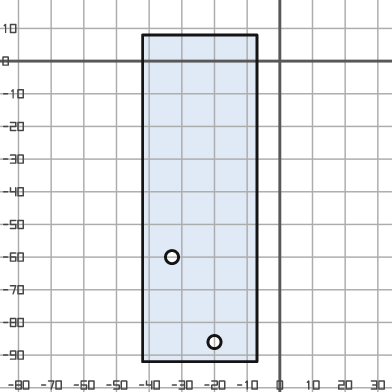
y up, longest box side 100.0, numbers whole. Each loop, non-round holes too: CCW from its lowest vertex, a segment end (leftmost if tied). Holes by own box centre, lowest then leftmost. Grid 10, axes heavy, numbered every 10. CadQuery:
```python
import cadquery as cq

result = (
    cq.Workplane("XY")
    .moveTo(-42.0, -92.0)
    .lineTo(-7.0, -92.0)
    .lineTo(-7.0, 8.0)
    .lineTo(-42.0, 8.0)
    .close()
    .moveTo(-20.0, -86.0)
    .circle(2.0)
    .moveTo(-33.0, -60.0)
    .circle(2.0)
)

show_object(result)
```